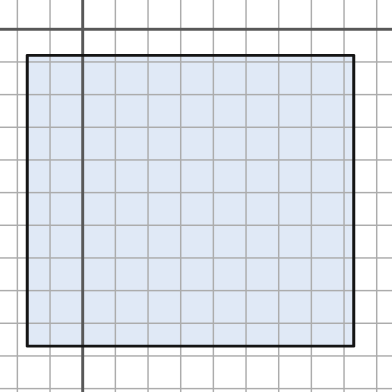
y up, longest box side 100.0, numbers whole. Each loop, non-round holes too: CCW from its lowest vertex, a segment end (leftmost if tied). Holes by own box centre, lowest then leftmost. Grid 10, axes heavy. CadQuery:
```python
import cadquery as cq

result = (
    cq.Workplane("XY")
    .moveTo(-17.0, -97.0)
    .lineTo(83.0, -97.0)
    .lineTo(83.0, -8.0)
    .lineTo(-17.0, -8.0)
    .close()
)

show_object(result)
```